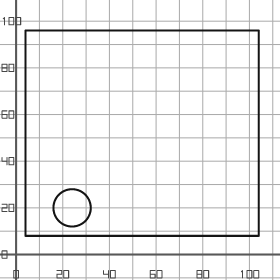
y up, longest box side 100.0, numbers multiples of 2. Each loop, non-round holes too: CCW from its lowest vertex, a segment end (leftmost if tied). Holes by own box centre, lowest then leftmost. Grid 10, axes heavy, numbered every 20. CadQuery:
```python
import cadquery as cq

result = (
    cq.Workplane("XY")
    .moveTo(4.0, 8.0)
    .lineTo(104.0, 8.0)
    .lineTo(104.0, 96.0)
    .lineTo(4.0, 96.0)
    .close()
    .moveTo(24.0, 20.0)
    .circle(8.0)
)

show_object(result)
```